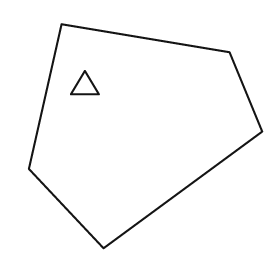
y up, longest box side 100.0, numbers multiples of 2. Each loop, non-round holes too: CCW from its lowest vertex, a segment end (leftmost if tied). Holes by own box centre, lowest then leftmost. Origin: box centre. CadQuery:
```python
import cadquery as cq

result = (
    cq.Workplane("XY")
    .moveTo(-18.0, -48.0)
    .lineTo(50.0, 2.0)
    .lineTo(36.0, 36.0)
    .lineTo(-36.0, 48.0)
    .lineTo(-50.0, -14.0)
    .close()
    .moveTo(-32.0, 18.0)
    .lineTo(-20.0, 18.0)
    .lineTo(-26.0, 28.0)
    .close()
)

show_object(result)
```